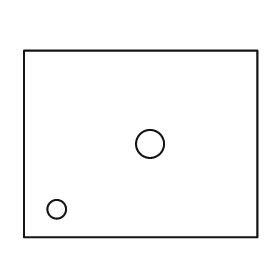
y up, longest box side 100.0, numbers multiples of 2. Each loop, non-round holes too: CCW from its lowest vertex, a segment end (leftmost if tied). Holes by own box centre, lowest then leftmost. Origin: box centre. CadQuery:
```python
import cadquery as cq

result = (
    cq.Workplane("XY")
    .moveTo(-50.0, -40.0)
    .lineTo(50.0, -40.0)
    .lineTo(50.0, 40.0)
    .lineTo(-50.0, 40.0)
    .close()
    .moveTo(-36.0, -28.0)
    .circle(4.0)
    .moveTo(4.0, 0.0)
    .circle(6.0)
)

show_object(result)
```